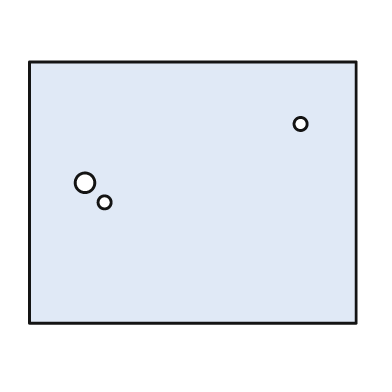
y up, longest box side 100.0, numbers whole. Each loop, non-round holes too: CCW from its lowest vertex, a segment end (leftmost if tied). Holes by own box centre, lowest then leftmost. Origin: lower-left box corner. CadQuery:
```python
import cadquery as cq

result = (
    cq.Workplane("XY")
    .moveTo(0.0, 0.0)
    .lineTo(100.0, 0.0)
    .lineTo(100.0, 80.0)
    .lineTo(0.0, 80.0)
    .close()
    .moveTo(23.0, 37.0)
    .circle(2.0)
    .moveTo(17.0, 43.0)
    .circle(3.0)
    .moveTo(83.0, 61.0)
    .circle(2.0)
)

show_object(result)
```